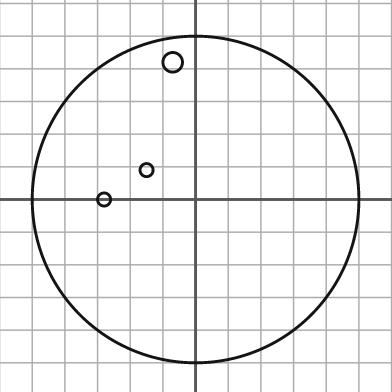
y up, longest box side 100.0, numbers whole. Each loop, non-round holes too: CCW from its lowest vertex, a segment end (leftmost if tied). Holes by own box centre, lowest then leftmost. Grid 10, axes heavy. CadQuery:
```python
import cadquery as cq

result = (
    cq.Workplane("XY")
    .moveTo(0.0, 0.0)
    .circle(50.0)
    .moveTo(-28.0, 0.0)
    .circle(2.0)
    .moveTo(-15.0, 9.0)
    .circle(2.0)
    .moveTo(-7.0, 42.0)
    .circle(3.0)
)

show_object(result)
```